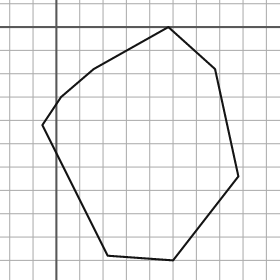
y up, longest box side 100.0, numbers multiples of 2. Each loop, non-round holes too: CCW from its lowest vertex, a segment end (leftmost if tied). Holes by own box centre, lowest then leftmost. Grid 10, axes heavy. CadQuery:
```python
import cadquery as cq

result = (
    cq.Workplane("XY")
    .moveTo(50.0, -100.0)
    .lineTo(78.0, -64.0)
    .lineTo(68.0, -18.0)
    .lineTo(48.0, 0.0)
    .lineTo(16.0, -18.0)
    .lineTo(2.0, -30.0)
    .lineTo(-6.0, -42.0)
    .lineTo(22.0, -98.0)
    .close()
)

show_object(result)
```